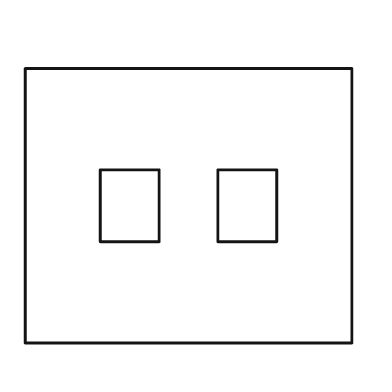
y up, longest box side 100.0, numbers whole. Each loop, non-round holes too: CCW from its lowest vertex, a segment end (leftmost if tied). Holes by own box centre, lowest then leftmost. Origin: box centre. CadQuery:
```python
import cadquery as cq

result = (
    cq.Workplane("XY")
    .moveTo(-50.0, -42.0)
    .lineTo(50.0, -42.0)
    .lineTo(50.0, 42.0)
    .lineTo(-50.0, 42.0)
    .close()
    .moveTo(-27.0, -11.0)
    .lineTo(-9.0, -11.0)
    .lineTo(-9.0, 11.0)
    .lineTo(-27.0, 11.0)
    .close()
    .moveTo(9.0, -11.0)
    .lineTo(27.0, -11.0)
    .lineTo(27.0, 11.0)
    .lineTo(9.0, 11.0)
    .close()
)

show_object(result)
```